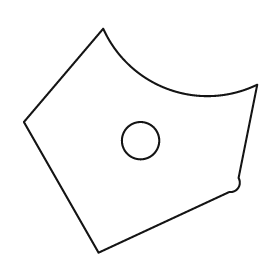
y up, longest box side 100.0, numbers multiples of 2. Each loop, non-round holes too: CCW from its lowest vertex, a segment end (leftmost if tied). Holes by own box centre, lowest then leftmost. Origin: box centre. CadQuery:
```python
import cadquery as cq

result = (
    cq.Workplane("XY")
    .moveTo(-18.0, -48.0)
    .lineTo(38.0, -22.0)
    .threePointArc((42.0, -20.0), (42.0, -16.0))
    .lineTo(50.0, 24.0)
    .threePointArc((12.0, 22.0), (-16.0, 48.0))
    .lineTo(-50.0, 8.0)
    .close()
    .moveTo(0.0, 0.0)
    .circle(8.0)
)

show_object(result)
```